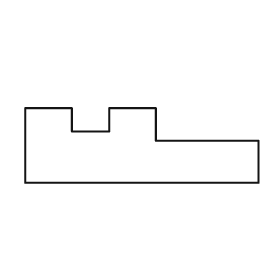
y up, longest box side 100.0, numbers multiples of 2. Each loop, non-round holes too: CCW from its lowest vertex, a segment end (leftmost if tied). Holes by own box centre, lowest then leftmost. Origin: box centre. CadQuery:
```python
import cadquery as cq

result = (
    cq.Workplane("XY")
    .moveTo(-50.0, -16.0)
    .lineTo(50.0, -16.0)
    .lineTo(50.0, 2.0)
    .lineTo(6.0, 2.0)
    .lineTo(6.0, 16.0)
    .lineTo(-14.0, 16.0)
    .lineTo(-14.0, 6.0)
    .lineTo(-30.0, 6.0)
    .lineTo(-30.0, 16.0)
    .lineTo(-50.0, 16.0)
    .close()
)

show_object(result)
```